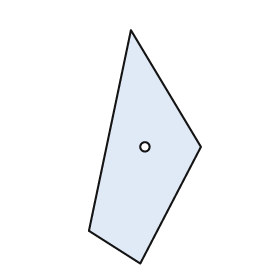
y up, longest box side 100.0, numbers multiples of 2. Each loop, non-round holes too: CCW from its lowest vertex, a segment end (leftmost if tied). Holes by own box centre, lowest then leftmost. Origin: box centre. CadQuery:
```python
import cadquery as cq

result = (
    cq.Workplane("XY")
    .moveTo(-2.0, -50.0)
    .lineTo(24.0, 0.0)
    .lineTo(-6.0, 50.0)
    .lineTo(-24.0, -36.0)
    .close()
    .moveTo(0.0, 0.0)
    .circle(2.0)
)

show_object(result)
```